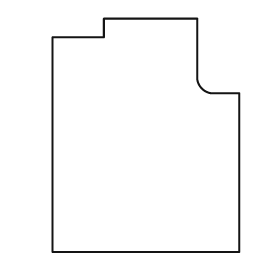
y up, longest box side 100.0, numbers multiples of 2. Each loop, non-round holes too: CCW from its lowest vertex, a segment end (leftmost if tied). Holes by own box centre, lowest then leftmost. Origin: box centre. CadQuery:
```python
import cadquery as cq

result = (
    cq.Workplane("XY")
    .moveTo(-40.0, -50.0)
    .lineTo(40.0, -50.0)
    .lineTo(40.0, 18.0)
    .lineTo(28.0, 18.0)
    .threePointArc((24.0, 20.0), (22.0, 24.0))
    .lineTo(22.0, 50.0)
    .lineTo(-18.0, 50.0)
    .lineTo(-18.0, 42.0)
    .lineTo(-40.0, 42.0)
    .close()
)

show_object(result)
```